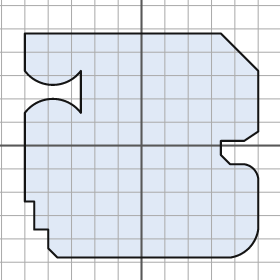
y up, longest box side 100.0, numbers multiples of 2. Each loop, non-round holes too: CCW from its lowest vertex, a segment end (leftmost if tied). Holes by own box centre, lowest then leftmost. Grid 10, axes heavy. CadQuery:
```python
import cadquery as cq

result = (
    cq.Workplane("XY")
    .moveTo(-36.0, -48.0)
    .lineTo(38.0, -48.0)
    .threePointArc((46.0, -44.0), (50.0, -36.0))
    .lineTo(50.0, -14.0)
    .threePointArc((48.0, -10.0), (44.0, -8.0))
    .lineTo(38.0, -8.0)
    .lineTo(34.0, -4.0)
    .lineTo(34.0, 2.0)
    .lineTo(44.0, 2.0)
    .lineTo(50.0, 6.0)
    .lineTo(50.0, 32.0)
    .lineTo(34.0, 48.0)
    .lineTo(-50.0, 48.0)
    .lineTo(-50.0, 32.0)
    .threePointArc((-38.0, 26.0), (-26.0, 32.0))
    .lineTo(-26.0, 14.0)
    .threePointArc((-38.0, 20.0), (-50.0, 14.0))
    .lineTo(-50.0, -24.0)
    .lineTo(-46.0, -24.0)
    .lineTo(-46.0, -36.0)
    .lineTo(-40.0, -36.0)
    .lineTo(-40.0, -44.0)
    .close()
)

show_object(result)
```